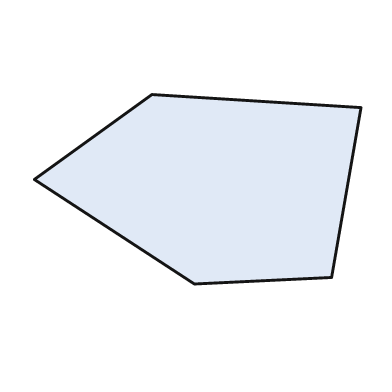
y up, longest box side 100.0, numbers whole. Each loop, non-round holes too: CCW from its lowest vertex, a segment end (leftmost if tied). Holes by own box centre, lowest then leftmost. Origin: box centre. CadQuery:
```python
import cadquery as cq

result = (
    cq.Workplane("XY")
    .moveTo(-1.0, -29.0)
    .lineTo(41.0, -27.0)
    .lineTo(50.0, 25.0)
    .lineTo(-14.0, 29.0)
    .lineTo(-50.0, 3.0)
    .close()
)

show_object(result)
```